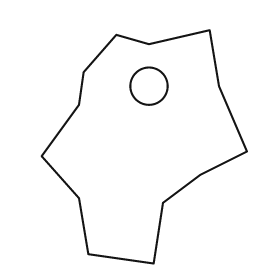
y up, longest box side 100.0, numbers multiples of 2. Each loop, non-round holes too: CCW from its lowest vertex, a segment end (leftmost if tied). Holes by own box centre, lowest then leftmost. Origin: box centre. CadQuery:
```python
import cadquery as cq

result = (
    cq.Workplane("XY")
    .moveTo(4.0, -50.0)
    .lineTo(8.0, -24.0)
    .lineTo(24.0, -12.0)
    .lineTo(44.0, -2.0)
    .lineTo(32.0, 26.0)
    .lineTo(28.0, 50.0)
    .lineTo(2.0, 44.0)
    .lineTo(-12.0, 48.0)
    .lineTo(-26.0, 32.0)
    .lineTo(-28.0, 18.0)
    .lineTo(-44.0, -4.0)
    .lineTo(-28.0, -22.0)
    .lineTo(-24.0, -46.0)
    .close()
    .moveTo(2.0, 26.0)
    .circle(8.0)
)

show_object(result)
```